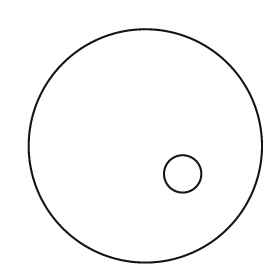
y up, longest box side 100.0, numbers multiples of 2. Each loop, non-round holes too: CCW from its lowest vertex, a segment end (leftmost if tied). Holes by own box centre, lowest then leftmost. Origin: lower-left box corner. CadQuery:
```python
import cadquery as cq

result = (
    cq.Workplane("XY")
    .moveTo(50.0, 50.0)
    .circle(50.0)
    .moveTo(66.0, 38.0)
    .circle(8.0)
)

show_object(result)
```